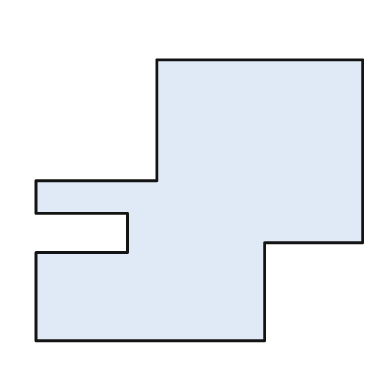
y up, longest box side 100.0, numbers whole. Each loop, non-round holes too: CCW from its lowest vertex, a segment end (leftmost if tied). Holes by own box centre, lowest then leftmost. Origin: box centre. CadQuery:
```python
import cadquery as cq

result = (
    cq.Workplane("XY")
    .moveTo(-50.0, -43.0)
    .lineTo(20.0, -43.0)
    .lineTo(20.0, -13.0)
    .lineTo(50.0, -13.0)
    .lineTo(50.0, 43.0)
    .lineTo(-13.0, 43.0)
    .lineTo(-13.0, 6.0)
    .lineTo(-50.0, 6.0)
    .lineTo(-50.0, -4.0)
    .lineTo(-22.0, -4.0)
    .lineTo(-22.0, -16.0)
    .lineTo(-50.0, -16.0)
    .close()
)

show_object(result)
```